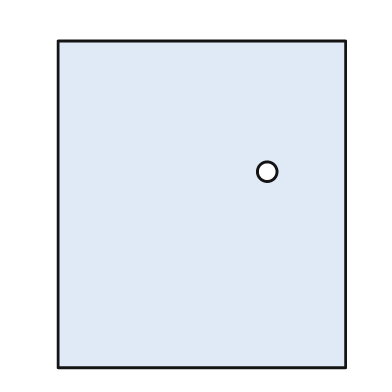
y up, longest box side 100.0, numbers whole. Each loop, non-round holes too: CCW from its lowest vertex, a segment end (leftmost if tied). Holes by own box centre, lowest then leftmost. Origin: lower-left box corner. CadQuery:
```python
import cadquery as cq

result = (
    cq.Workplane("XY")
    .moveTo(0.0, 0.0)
    .lineTo(88.0, 0.0)
    .lineTo(88.0, 100.0)
    .lineTo(0.0, 100.0)
    .close()
    .moveTo(64.0, 60.0)
    .circle(3.0)
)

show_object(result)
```